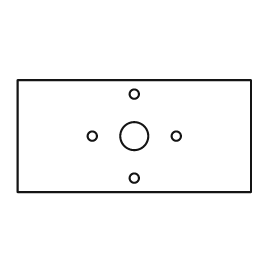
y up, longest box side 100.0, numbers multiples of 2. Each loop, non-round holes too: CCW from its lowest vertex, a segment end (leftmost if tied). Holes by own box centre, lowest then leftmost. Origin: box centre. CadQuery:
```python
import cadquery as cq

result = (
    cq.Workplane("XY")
    .moveTo(-50.0, -24.0)
    .lineTo(50.0, -24.0)
    .lineTo(50.0, 24.0)
    .lineTo(-50.0, 24.0)
    .close()
    .moveTo(0.0, -18.0)
    .circle(2.0)
    .moveTo(-18.0, 0.0)
    .circle(2.0)
    .moveTo(0.0, 0.0)
    .circle(6.0)
    .moveTo(18.0, 0.0)
    .circle(2.0)
    .moveTo(0.0, 18.0)
    .circle(2.0)
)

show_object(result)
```